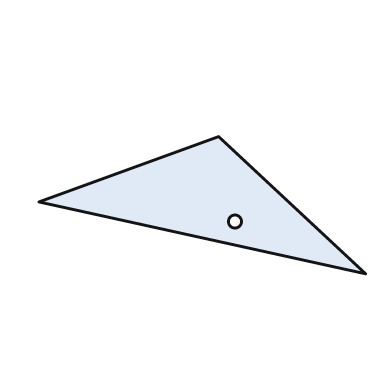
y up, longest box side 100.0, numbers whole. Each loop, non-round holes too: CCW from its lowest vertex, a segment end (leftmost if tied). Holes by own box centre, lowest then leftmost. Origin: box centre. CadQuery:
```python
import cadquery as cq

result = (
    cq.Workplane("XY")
    .moveTo(50.0, -21.0)
    .lineTo(5.0, 21.0)
    .lineTo(-50.0, 1.0)
    .close()
    .moveTo(10.0, -5.0)
    .circle(2.0)
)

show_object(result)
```